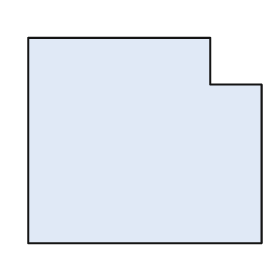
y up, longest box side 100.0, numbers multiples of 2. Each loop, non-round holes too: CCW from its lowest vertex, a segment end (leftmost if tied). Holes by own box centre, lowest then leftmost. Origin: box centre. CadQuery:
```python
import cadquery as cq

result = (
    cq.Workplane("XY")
    .moveTo(-50.0, -44.0)
    .lineTo(50.0, -44.0)
    .lineTo(50.0, 24.0)
    .lineTo(28.0, 24.0)
    .lineTo(28.0, 44.0)
    .lineTo(-50.0, 44.0)
    .close()
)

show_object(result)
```